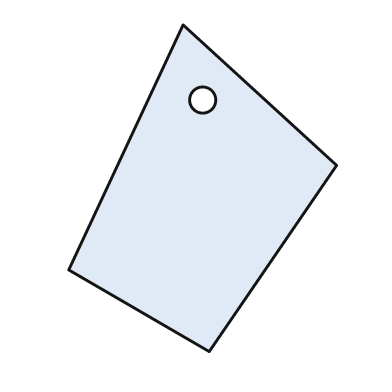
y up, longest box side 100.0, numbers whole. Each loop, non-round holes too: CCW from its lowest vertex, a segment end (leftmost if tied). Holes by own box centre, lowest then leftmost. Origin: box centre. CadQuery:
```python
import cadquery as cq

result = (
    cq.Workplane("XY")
    .moveTo(2.0, -50.0)
    .lineTo(41.0, 7.0)
    .lineTo(-6.0, 50.0)
    .lineTo(-41.0, -25.0)
    .close()
    .moveTo(0.0, 27.0)
    .circle(4.0)
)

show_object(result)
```